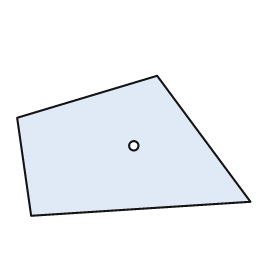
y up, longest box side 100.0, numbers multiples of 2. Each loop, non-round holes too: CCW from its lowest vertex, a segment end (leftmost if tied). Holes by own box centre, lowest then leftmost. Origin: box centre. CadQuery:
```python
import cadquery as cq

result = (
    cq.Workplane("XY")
    .moveTo(-44.0, -30.0)
    .lineTo(50.0, -24.0)
    .lineTo(10.0, 30.0)
    .lineTo(-50.0, 12.0)
    .close()
    .moveTo(0.0, 0.0)
    .circle(2.0)
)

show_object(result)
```